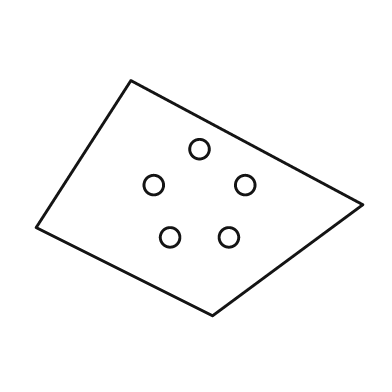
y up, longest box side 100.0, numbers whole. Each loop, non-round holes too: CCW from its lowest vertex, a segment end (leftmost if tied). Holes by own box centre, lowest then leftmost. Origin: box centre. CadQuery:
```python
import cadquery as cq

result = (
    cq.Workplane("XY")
    .moveTo(4.0, -36.0)
    .lineTo(50.0, -2.0)
    .lineTo(-21.0, 36.0)
    .lineTo(-50.0, -9.0)
    .close()
    .moveTo(-9.0, -12.0)
    .circle(3.0)
    .moveTo(9.0, -12.0)
    .circle(3.0)
    .moveTo(-14.0, 4.0)
    .circle(3.0)
    .moveTo(14.0, 4.0)
    .circle(3.0)
    .moveTo(0.0, 15.0)
    .circle(3.0)
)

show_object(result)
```